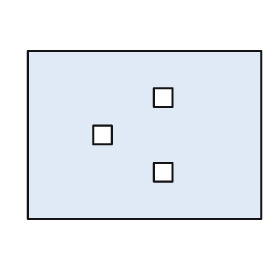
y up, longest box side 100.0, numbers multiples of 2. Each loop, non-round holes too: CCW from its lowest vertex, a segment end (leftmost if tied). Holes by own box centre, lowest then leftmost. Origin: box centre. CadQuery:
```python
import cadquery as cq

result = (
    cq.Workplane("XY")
    .moveTo(-50.0, -36.0)
    .lineTo(50.0, -36.0)
    .lineTo(50.0, 36.0)
    .lineTo(-50.0, 36.0)
    .close()
    .moveTo(4.0, -20.0)
    .lineTo(12.0, -20.0)
    .lineTo(12.0, -12.0)
    .lineTo(4.0, -12.0)
    .close()
    .moveTo(-22.0, -4.0)
    .lineTo(-14.0, -4.0)
    .lineTo(-14.0, 4.0)
    .lineTo(-22.0, 4.0)
    .close()
    .moveTo(4.0, 12.0)
    .lineTo(12.0, 12.0)
    .lineTo(12.0, 20.0)
    .lineTo(4.0, 20.0)
    .close()
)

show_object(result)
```